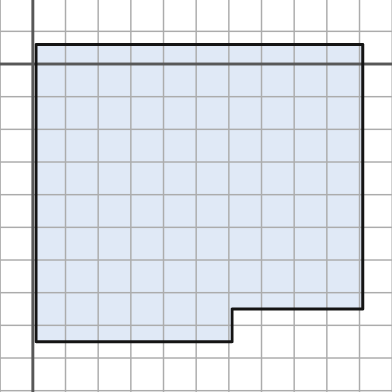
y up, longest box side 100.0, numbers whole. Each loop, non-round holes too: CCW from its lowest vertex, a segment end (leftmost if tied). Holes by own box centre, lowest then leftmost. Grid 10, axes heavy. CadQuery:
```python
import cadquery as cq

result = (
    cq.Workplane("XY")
    .moveTo(1.0, -85.0)
    .lineTo(61.0, -85.0)
    .lineTo(61.0, -75.0)
    .lineTo(101.0, -75.0)
    .lineTo(101.0, 6.0)
    .lineTo(1.0, 6.0)
    .close()
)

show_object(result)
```